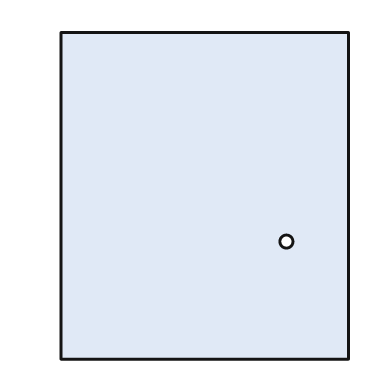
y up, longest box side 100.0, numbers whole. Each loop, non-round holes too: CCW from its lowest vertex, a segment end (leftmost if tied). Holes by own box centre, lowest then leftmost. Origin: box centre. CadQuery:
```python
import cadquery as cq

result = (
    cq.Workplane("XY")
    .moveTo(-44.0, -50.0)
    .lineTo(44.0, -50.0)
    .lineTo(44.0, 50.0)
    .lineTo(-44.0, 50.0)
    .close()
    .moveTo(25.0, -14.0)
    .circle(2.0)
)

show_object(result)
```